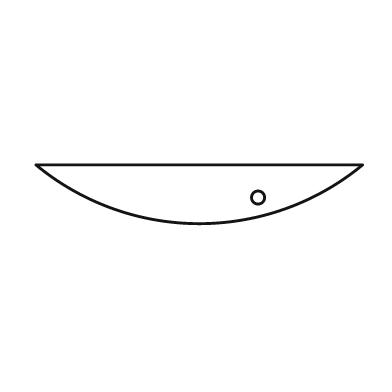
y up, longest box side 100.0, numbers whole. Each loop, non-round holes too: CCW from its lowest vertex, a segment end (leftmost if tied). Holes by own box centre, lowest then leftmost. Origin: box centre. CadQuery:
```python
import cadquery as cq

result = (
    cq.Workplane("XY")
    .moveTo(-50.0, 9.0)
    .threePointArc((0.0, -9.0), (50.0, 9.0))
    .close()
    .moveTo(18.0, -1.0)
    .circle(2.0)
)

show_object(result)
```